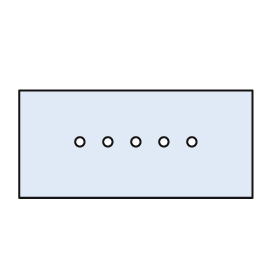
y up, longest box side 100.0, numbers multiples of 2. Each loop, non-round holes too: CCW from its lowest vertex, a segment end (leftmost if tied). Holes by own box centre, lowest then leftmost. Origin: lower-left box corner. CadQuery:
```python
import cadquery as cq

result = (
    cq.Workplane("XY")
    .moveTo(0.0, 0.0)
    .lineTo(100.0, 0.0)
    .lineTo(100.0, 46.0)
    .lineTo(0.0, 46.0)
    .close()
    .moveTo(26.0, 24.0)
    .circle(2.0)
    .moveTo(38.0, 24.0)
    .circle(2.0)
    .moveTo(50.0, 24.0)
    .circle(2.0)
    .moveTo(62.0, 24.0)
    .circle(2.0)
    .moveTo(74.0, 24.0)
    .circle(2.0)
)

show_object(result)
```